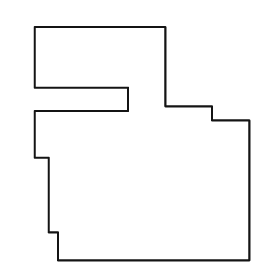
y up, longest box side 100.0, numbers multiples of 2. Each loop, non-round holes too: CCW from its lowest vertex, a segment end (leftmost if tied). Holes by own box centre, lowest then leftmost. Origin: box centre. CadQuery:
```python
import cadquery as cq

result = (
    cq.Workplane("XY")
    .moveTo(-36.0, -50.0)
    .lineTo(46.0, -50.0)
    .lineTo(46.0, 10.0)
    .lineTo(30.0, 10.0)
    .lineTo(30.0, 16.0)
    .lineTo(10.0, 16.0)
    .lineTo(10.0, 50.0)
    .lineTo(-46.0, 50.0)
    .lineTo(-46.0, 24.0)
    .lineTo(-6.0, 24.0)
    .lineTo(-6.0, 14.0)
    .lineTo(-46.0, 14.0)
    .lineTo(-46.0, -6.0)
    .lineTo(-40.0, -6.0)
    .lineTo(-40.0, -38.0)
    .lineTo(-36.0, -38.0)
    .close()
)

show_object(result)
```